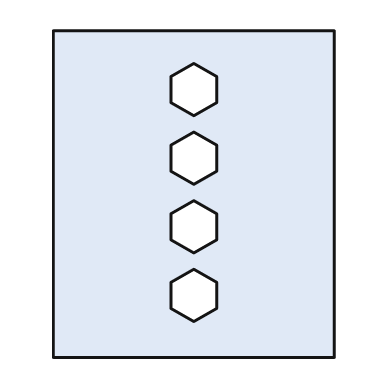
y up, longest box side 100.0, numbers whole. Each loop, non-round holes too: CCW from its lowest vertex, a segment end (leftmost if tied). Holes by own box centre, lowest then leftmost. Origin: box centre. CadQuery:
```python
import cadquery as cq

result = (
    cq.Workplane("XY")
    .moveTo(-43.0, -50.0)
    .lineTo(43.0, -50.0)
    .lineTo(43.0, 50.0)
    .lineTo(-43.0, 50.0)
    .close()
    .moveTo(0.0, -39.0)
    .lineTo(7.0, -35.0)
    .lineTo(7.0, -27.0)
    .lineTo(0.0, -23.0)
    .lineTo(-7.0, -27.0)
    .lineTo(-7.0, -35.0)
    .close()
    .moveTo(0.0, -18.0)
    .lineTo(7.0, -14.0)
    .lineTo(7.0, -6.0)
    .lineTo(0.0, -2.0)
    .lineTo(-7.0, -6.0)
    .lineTo(-7.0, -14.0)
    .close()
    .moveTo(0.0, 3.0)
    .lineTo(7.0, 7.0)
    .lineTo(7.0, 15.0)
    .lineTo(0.0, 19.0)
    .lineTo(-7.0, 15.0)
    .lineTo(-7.0, 7.0)
    .close()
    .moveTo(0.0, 24.0)
    .lineTo(7.0, 28.0)
    .lineTo(7.0, 36.0)
    .lineTo(0.0, 40.0)
    .lineTo(-7.0, 36.0)
    .lineTo(-7.0, 28.0)
    .close()
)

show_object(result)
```